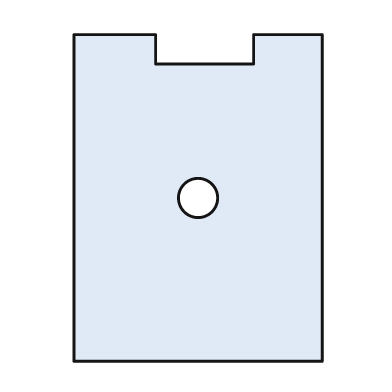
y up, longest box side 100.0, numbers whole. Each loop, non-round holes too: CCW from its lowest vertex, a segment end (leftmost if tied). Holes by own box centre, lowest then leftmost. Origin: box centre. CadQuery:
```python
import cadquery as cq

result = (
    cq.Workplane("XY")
    .moveTo(-38.0, -50.0)
    .lineTo(38.0, -50.0)
    .lineTo(38.0, 50.0)
    .lineTo(17.0, 50.0)
    .lineTo(17.0, 41.0)
    .lineTo(-13.0, 41.0)
    .lineTo(-13.0, 50.0)
    .lineTo(-38.0, 50.0)
    .close()
    .moveTo(0.0, 0.0)
    .circle(6.0)
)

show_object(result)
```